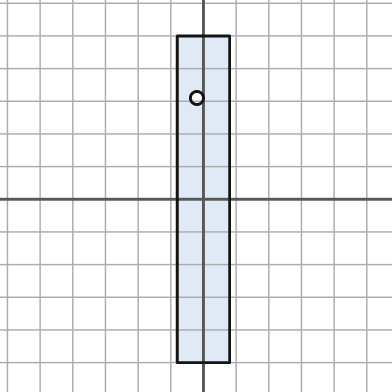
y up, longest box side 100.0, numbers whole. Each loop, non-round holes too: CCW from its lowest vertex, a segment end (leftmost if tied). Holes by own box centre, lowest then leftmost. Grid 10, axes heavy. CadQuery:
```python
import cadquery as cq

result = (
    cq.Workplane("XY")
    .moveTo(-8.0, -50.0)
    .lineTo(8.0, -50.0)
    .lineTo(8.0, 50.0)
    .lineTo(-8.0, 50.0)
    .close()
    .moveTo(-2.0, 31.0)
    .circle(2.0)
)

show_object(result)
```